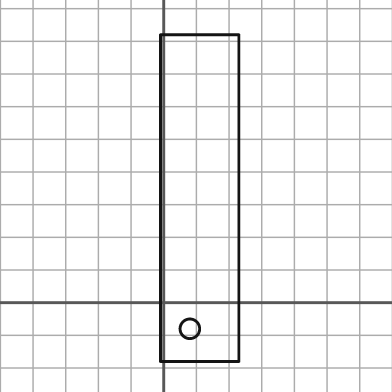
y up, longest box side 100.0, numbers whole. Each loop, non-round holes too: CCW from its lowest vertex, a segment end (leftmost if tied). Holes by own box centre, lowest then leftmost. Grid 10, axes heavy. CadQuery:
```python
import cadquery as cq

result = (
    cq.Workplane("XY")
    .moveTo(-1.0, -18.0)
    .lineTo(23.0, -18.0)
    .lineTo(23.0, 82.0)
    .lineTo(-1.0, 82.0)
    .close()
    .moveTo(8.0, -8.0)
    .circle(3.0)
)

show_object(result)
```